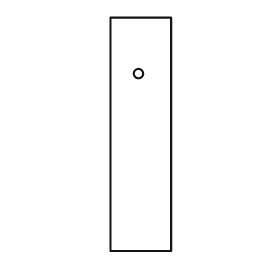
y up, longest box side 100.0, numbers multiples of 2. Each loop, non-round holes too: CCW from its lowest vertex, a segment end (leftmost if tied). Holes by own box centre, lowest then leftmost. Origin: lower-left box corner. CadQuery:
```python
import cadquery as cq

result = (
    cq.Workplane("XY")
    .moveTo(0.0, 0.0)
    .lineTo(26.0, 0.0)
    .lineTo(26.0, 100.0)
    .lineTo(0.0, 100.0)
    .close()
    .moveTo(12.0, 76.0)
    .circle(2.0)
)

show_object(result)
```